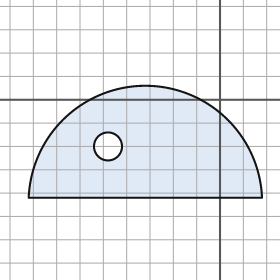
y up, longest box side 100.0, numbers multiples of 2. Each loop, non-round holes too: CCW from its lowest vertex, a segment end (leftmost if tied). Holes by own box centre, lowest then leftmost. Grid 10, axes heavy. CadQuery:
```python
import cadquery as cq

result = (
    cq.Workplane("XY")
    .moveTo(-82.0, -42.0)
    .lineTo(18.0, -42.0)
    .threePointArc((-32.0, 6.0), (-82.0, -42.0))
    .close()
    .moveTo(-48.0, -20.0)
    .circle(6.0)
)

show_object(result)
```